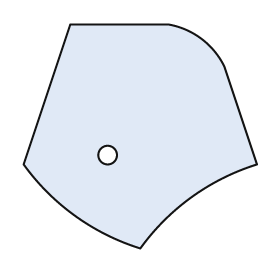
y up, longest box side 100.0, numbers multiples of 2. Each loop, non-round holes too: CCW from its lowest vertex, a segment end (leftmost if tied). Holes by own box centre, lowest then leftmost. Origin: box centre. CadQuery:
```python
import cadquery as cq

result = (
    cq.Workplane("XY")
    .moveTo(0.0, -48.0)
    .threePointArc((22.0, -26.0), (50.0, -12.0))
    .lineTo(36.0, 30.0)
    .threePointArc((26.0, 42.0), (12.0, 48.0))
    .lineTo(-30.0, 48.0)
    .lineTo(-50.0, -12.0)
    .threePointArc((-28.0, -34.0), (0.0, -48.0))
    .close()
    .moveTo(-14.0, -8.0)
    .circle(4.0)
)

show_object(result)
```